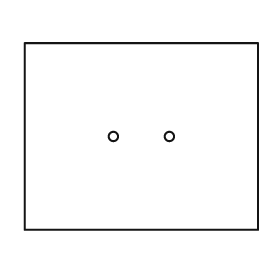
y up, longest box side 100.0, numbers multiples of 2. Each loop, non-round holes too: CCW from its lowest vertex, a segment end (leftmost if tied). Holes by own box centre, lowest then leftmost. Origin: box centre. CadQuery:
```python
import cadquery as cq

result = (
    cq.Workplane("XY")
    .moveTo(-50.0, -40.0)
    .lineTo(50.0, -40.0)
    .lineTo(50.0, 40.0)
    .lineTo(-50.0, 40.0)
    .close()
    .moveTo(-12.0, 0.0)
    .circle(2.0)
    .moveTo(12.0, 0.0)
    .circle(2.0)
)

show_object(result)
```